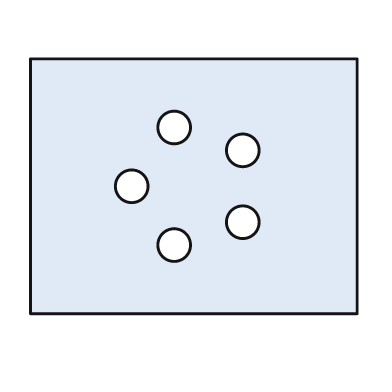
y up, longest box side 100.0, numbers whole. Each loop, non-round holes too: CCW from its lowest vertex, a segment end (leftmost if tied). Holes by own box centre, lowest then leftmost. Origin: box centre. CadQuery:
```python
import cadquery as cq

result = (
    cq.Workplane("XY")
    .moveTo(-50.0, -39.0)
    .lineTo(50.0, -39.0)
    .lineTo(50.0, 39.0)
    .lineTo(-50.0, 39.0)
    .close()
    .moveTo(-6.0, -18.0)
    .circle(5.0)
    .moveTo(15.0, -11.0)
    .circle(5.0)
    .moveTo(-19.0, 0.0)
    .circle(5.0)
    .moveTo(15.0, 11.0)
    .circle(5.0)
    .moveTo(-6.0, 18.0)
    .circle(5.0)
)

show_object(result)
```